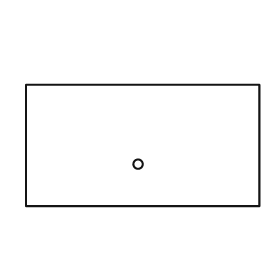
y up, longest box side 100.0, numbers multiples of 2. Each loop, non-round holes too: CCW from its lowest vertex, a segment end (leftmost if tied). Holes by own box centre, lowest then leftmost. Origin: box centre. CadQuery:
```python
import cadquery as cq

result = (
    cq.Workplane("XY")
    .moveTo(-50.0, -26.0)
    .lineTo(50.0, -26.0)
    .lineTo(50.0, 26.0)
    .lineTo(-50.0, 26.0)
    .close()
    .moveTo(-2.0, -8.0)
    .circle(2.0)
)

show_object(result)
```